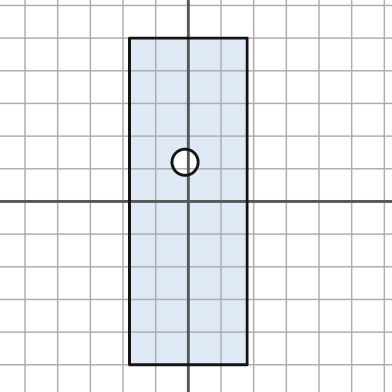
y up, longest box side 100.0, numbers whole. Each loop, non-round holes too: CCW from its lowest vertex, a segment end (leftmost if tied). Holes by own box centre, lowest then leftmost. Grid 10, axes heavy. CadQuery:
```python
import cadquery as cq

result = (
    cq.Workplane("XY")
    .moveTo(-18.0, -50.0)
    .lineTo(18.0, -50.0)
    .lineTo(18.0, 50.0)
    .lineTo(-18.0, 50.0)
    .close()
    .moveTo(-1.0, 12.0)
    .circle(4.0)
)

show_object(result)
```